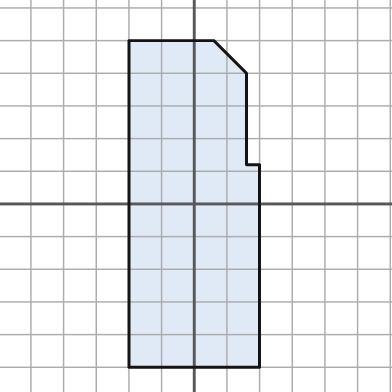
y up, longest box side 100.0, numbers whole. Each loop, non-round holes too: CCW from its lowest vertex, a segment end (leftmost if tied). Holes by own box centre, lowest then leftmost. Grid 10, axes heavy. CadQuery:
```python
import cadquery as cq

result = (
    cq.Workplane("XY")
    .moveTo(-20.0, -50.0)
    .lineTo(20.0, -50.0)
    .lineTo(20.0, 12.0)
    .lineTo(16.0, 12.0)
    .lineTo(16.0, 40.0)
    .lineTo(6.0, 50.0)
    .lineTo(-20.0, 50.0)
    .close()
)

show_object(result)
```